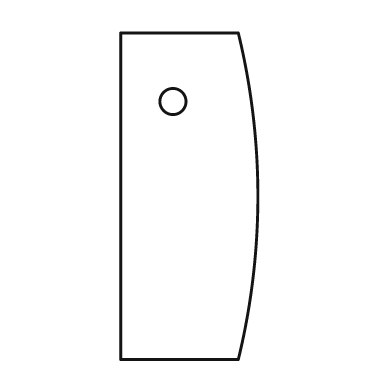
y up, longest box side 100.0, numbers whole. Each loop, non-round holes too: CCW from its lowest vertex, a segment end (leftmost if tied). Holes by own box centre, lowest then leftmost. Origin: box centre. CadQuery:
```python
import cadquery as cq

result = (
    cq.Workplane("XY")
    .moveTo(-21.0, -50.0)
    .lineTo(15.0, -50.0)
    .threePointArc((21.0, 0.0), (15.0, 50.0))
    .lineTo(-21.0, 50.0)
    .close()
    .moveTo(-5.0, 29.0)
    .circle(4.0)
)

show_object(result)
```